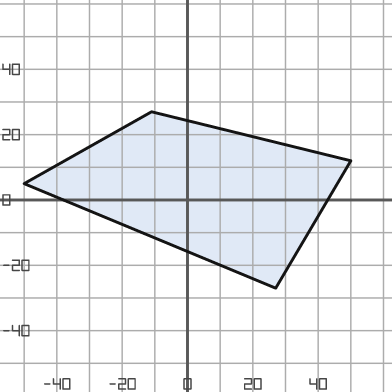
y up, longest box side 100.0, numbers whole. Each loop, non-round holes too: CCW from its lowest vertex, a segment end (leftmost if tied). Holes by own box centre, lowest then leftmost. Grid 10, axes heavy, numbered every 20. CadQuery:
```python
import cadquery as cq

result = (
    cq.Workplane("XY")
    .moveTo(27.0, -27.0)
    .lineTo(50.0, 12.0)
    .lineTo(-11.0, 27.0)
    .lineTo(-50.0, 5.0)
    .close()
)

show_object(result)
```